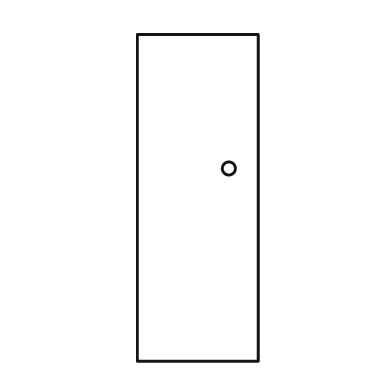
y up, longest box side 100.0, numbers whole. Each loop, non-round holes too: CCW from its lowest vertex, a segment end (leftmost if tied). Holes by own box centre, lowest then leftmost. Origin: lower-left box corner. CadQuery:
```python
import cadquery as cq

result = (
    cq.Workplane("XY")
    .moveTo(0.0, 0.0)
    .lineTo(37.0, 0.0)
    .lineTo(37.0, 100.0)
    .lineTo(0.0, 100.0)
    .close()
    .moveTo(28.0, 59.0)
    .circle(2.0)
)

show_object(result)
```